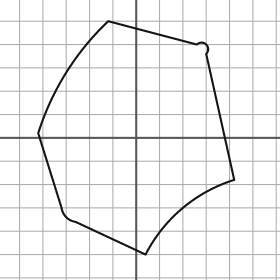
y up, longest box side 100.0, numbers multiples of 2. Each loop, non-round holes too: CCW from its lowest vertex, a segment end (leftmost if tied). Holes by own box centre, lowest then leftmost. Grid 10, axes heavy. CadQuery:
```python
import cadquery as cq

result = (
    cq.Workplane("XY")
    .moveTo(4.0, -50.0)
    .threePointArc((20.0, -30.0), (42.0, -18.0))
    .lineTo(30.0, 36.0)
    .threePointArc((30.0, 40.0), (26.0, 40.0))
    .lineTo(-12.0, 50.0)
    .threePointArc((-30.0, 28.0), (-42.0, 2.0))
    .lineTo(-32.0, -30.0)
    .threePointArc((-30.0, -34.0), (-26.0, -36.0))
    .close()
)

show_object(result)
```